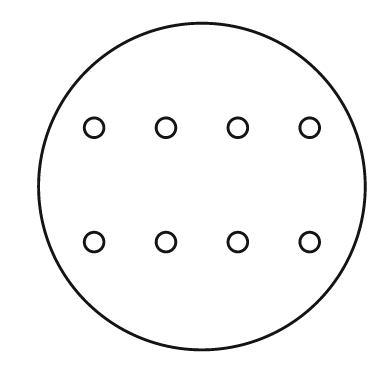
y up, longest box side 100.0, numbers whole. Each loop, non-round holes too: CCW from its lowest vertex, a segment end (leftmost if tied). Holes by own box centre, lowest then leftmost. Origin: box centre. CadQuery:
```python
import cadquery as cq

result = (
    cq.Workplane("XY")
    .moveTo(0.0, 0.0)
    .circle(50.0)
    .moveTo(-33.0, -17.0)
    .circle(3.0)
    .moveTo(-11.0, -17.0)
    .circle(3.0)
    .moveTo(11.0, -17.0)
    .circle(3.0)
    .moveTo(33.0, -17.0)
    .circle(3.0)
    .moveTo(-33.0, 18.0)
    .circle(3.0)
    .moveTo(-11.0, 18.0)
    .circle(3.0)
    .moveTo(11.0, 18.0)
    .circle(3.0)
    .moveTo(33.0, 18.0)
    .circle(3.0)
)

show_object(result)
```